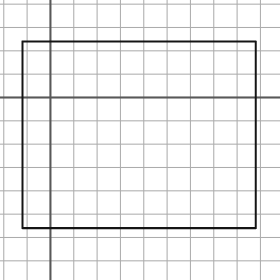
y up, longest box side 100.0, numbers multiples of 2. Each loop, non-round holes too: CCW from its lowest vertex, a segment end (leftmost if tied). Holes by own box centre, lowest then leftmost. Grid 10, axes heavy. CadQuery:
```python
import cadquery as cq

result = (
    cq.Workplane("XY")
    .moveTo(-12.0, -56.0)
    .lineTo(88.0, -56.0)
    .lineTo(88.0, 24.0)
    .lineTo(-12.0, 24.0)
    .close()
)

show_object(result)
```